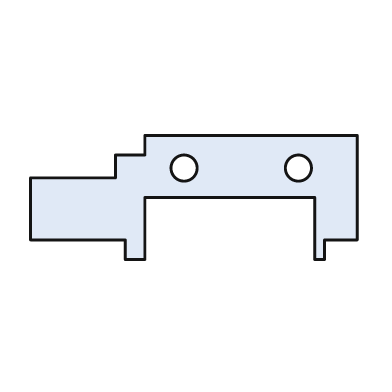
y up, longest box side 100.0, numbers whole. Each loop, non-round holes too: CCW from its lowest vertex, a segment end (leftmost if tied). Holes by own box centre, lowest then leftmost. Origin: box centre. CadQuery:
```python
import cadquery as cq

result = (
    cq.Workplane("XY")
    .moveTo(-21.0, -19.0)
    .lineTo(-15.0, -19.0)
    .lineTo(-15.0, 0.0)
    .lineTo(37.0, 0.0)
    .lineTo(37.0, -19.0)
    .lineTo(40.0, -19.0)
    .lineTo(40.0, -13.0)
    .lineTo(50.0, -13.0)
    .lineTo(50.0, 19.0)
    .lineTo(-15.0, 19.0)
    .lineTo(-15.0, 13.0)
    .lineTo(-24.0, 13.0)
    .lineTo(-24.0, 6.0)
    .lineTo(-50.0, 6.0)
    .lineTo(-50.0, -13.0)
    .lineTo(-21.0, -13.0)
    .close()
    .moveTo(-3.0, 9.0)
    .circle(4.0)
    .moveTo(32.0, 9.0)
    .circle(4.0)
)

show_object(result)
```